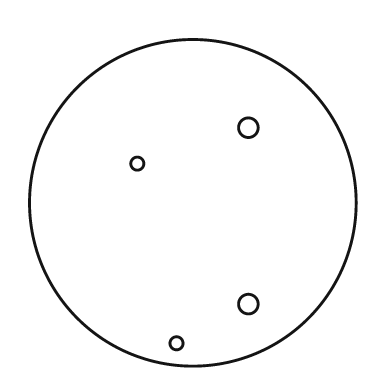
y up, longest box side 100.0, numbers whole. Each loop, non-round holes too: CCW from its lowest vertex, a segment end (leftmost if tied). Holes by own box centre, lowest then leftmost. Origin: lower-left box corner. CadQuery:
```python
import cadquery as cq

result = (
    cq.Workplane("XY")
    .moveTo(50.0, 50.0)
    .circle(50.0)
    .moveTo(45.0, 7.0)
    .circle(2.0)
    .moveTo(67.0, 19.0)
    .circle(3.0)
    .moveTo(33.0, 62.0)
    .circle(2.0)
    .moveTo(67.0, 73.0)
    .circle(3.0)
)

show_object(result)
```